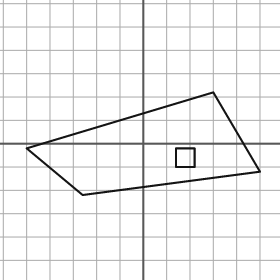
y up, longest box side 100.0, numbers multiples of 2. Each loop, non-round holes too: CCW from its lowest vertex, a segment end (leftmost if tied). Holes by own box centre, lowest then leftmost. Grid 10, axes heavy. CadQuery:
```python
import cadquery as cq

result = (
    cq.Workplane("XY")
    .moveTo(-26.0, -22.0)
    .lineTo(50.0, -12.0)
    .lineTo(30.0, 22.0)
    .lineTo(-50.0, -2.0)
    .close()
    .moveTo(14.0, -10.0)
    .lineTo(22.0, -10.0)
    .lineTo(22.0, -2.0)
    .lineTo(14.0, -2.0)
    .close()
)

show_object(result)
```